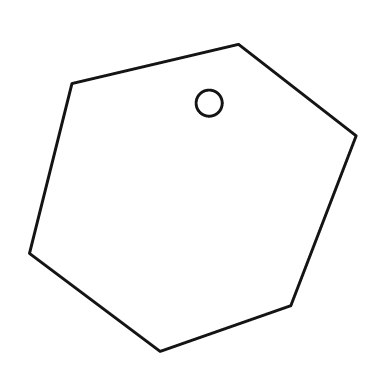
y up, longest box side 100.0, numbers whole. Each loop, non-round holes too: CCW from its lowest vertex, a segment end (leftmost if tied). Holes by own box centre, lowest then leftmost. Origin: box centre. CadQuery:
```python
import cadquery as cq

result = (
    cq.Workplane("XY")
    .moveTo(-10.0, -47.0)
    .lineTo(30.0, -33.0)
    .lineTo(50.0, 19.0)
    .lineTo(14.0, 47.0)
    .lineTo(-37.0, 35.0)
    .lineTo(-50.0, -17.0)
    .close()
    .moveTo(5.0, 29.0)
    .circle(4.0)
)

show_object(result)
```